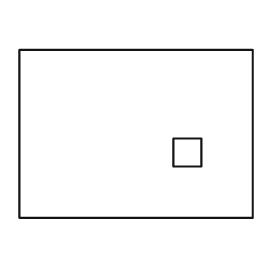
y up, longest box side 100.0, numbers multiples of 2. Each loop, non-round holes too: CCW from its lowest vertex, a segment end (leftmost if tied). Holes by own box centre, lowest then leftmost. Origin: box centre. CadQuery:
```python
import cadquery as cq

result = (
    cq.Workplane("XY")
    .moveTo(-50.0, -36.0)
    .lineTo(50.0, -36.0)
    .lineTo(50.0, 36.0)
    .lineTo(-50.0, 36.0)
    .close()
    .moveTo(16.0, -14.0)
    .lineTo(28.0, -14.0)
    .lineTo(28.0, -2.0)
    .lineTo(16.0, -2.0)
    .close()
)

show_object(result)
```